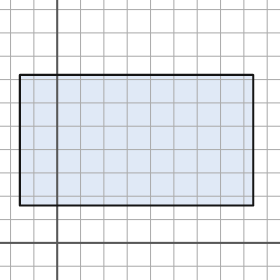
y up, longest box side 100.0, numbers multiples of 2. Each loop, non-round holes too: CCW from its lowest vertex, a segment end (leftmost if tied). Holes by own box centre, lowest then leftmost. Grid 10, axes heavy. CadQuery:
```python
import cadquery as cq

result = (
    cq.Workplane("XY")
    .moveTo(-16.0, 16.0)
    .lineTo(84.0, 16.0)
    .lineTo(84.0, 72.0)
    .lineTo(-16.0, 72.0)
    .close()
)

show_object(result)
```